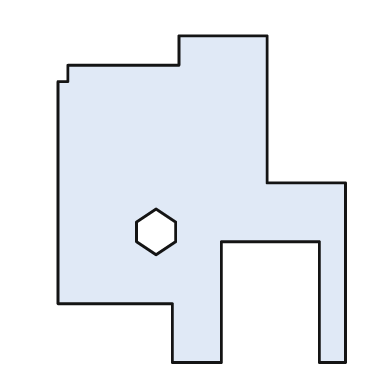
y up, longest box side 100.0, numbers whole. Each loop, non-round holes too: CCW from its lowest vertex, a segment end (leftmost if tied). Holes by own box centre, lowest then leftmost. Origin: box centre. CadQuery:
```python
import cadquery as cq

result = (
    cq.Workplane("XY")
    .moveTo(-9.0, -50.0)
    .lineTo(6.0, -50.0)
    .lineTo(6.0, -13.0)
    .lineTo(36.0, -13.0)
    .lineTo(36.0, -50.0)
    .lineTo(44.0, -50.0)
    .lineTo(44.0, 5.0)
    .lineTo(20.0, 5.0)
    .lineTo(20.0, 50.0)
    .lineTo(-7.0, 50.0)
    .lineTo(-7.0, 41.0)
    .lineTo(-41.0, 41.0)
    .lineTo(-41.0, 36.0)
    .lineTo(-44.0, 36.0)
    .lineTo(-44.0, -32.0)
    .lineTo(-9.0, -32.0)
    .close()
    .moveTo(-14.0, -17.0)
    .lineTo(-8.0, -13.0)
    .lineTo(-8.0, -7.0)
    .lineTo(-14.0, -3.0)
    .lineTo(-20.0, -7.0)
    .lineTo(-20.0, -13.0)
    .close()
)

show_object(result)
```